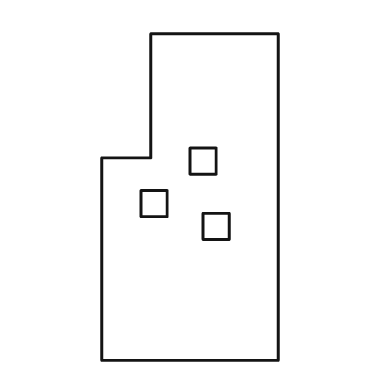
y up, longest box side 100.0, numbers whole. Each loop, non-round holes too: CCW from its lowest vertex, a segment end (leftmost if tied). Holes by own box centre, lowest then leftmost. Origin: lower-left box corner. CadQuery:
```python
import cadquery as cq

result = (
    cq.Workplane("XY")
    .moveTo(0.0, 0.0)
    .lineTo(54.0, 0.0)
    .lineTo(54.0, 100.0)
    .lineTo(15.0, 100.0)
    .lineTo(15.0, 62.0)
    .lineTo(0.0, 62.0)
    .close()
    .moveTo(31.0, 37.0)
    .lineTo(39.0, 37.0)
    .lineTo(39.0, 45.0)
    .lineTo(31.0, 45.0)
    .close()
    .moveTo(12.0, 44.0)
    .lineTo(20.0, 44.0)
    .lineTo(20.0, 52.0)
    .lineTo(12.0, 52.0)
    .close()
    .moveTo(27.0, 57.0)
    .lineTo(35.0, 57.0)
    .lineTo(35.0, 65.0)
    .lineTo(27.0, 65.0)
    .close()
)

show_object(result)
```